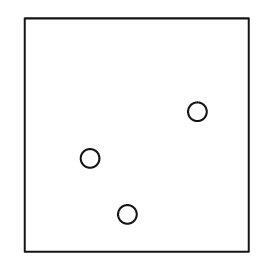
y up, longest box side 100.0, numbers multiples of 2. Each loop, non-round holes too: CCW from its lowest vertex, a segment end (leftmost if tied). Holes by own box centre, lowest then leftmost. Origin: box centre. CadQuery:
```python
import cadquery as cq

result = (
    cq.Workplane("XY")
    .moveTo(-48.0, -50.0)
    .lineTo(48.0, -50.0)
    .lineTo(48.0, 50.0)
    .lineTo(-48.0, 50.0)
    .close()
    .moveTo(-4.0, -34.0)
    .circle(4.0)
    .moveTo(-20.0, -10.0)
    .circle(4.0)
    .moveTo(26.0, 10.0)
    .circle(4.0)
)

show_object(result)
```